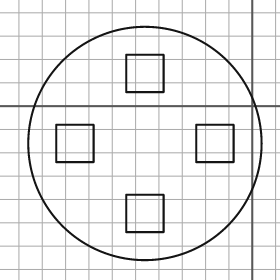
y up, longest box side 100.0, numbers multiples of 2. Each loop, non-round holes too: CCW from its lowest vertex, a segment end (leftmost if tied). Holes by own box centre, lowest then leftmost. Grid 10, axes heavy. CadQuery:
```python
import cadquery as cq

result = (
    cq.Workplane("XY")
    .moveTo(-46.0, -16.0)
    .circle(50.0)
    .moveTo(-54.0, -54.0)
    .lineTo(-38.0, -54.0)
    .lineTo(-38.0, -38.0)
    .lineTo(-54.0, -38.0)
    .close()
    .moveTo(-84.0, -24.0)
    .lineTo(-68.0, -24.0)
    .lineTo(-68.0, -8.0)
    .lineTo(-84.0, -8.0)
    .close()
    .moveTo(-24.0, -24.0)
    .lineTo(-8.0, -24.0)
    .lineTo(-8.0, -8.0)
    .lineTo(-24.0, -8.0)
    .close()
    .moveTo(-54.0, 6.0)
    .lineTo(-38.0, 6.0)
    .lineTo(-38.0, 22.0)
    .lineTo(-54.0, 22.0)
    .close()
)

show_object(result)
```